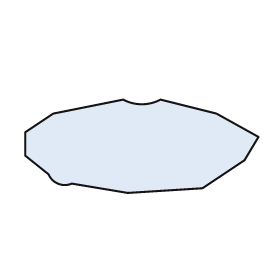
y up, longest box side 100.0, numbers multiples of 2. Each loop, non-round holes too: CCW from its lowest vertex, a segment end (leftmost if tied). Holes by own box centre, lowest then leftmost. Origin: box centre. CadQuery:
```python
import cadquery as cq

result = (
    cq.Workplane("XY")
    .moveTo(-6.0, -20.0)
    .lineTo(26.0, -18.0)
    .lineTo(44.0, -6.0)
    .lineTo(50.0, 4.0)
    .lineTo(32.0, 14.0)
    .lineTo(8.0, 20.0)
    .threePointArc((0.0, 18.0), (-8.0, 20.0))
    .lineTo(-38.0, 14.0)
    .lineTo(-50.0, 6.0)
    .lineTo(-50.0, -4.0)
    .lineTo(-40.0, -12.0)
    .threePointArc((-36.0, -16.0), (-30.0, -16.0))
    .close()
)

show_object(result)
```